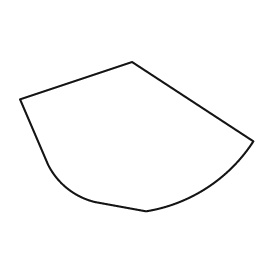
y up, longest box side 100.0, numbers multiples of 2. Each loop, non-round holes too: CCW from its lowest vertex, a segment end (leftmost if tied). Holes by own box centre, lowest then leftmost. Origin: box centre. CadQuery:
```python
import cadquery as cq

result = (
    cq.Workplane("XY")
    .moveTo(4.0, -32.0)
    .threePointArc((30.0, -22.0), (50.0, -2.0))
    .lineTo(-2.0, 32.0)
    .lineTo(-50.0, 16.0)
    .lineTo(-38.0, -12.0)
    .threePointArc((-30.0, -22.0), (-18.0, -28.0))
    .close()
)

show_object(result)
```